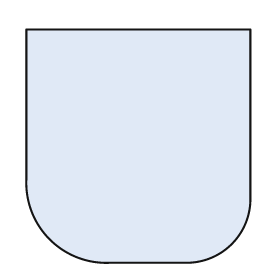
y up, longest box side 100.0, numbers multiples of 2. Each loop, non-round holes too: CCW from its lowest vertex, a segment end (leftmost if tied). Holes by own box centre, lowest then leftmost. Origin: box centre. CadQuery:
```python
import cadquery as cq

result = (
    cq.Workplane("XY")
    .moveTo(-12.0, -50.0)
    .lineTo(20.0, -50.0)
    .threePointArc((40.0, -42.0), (48.0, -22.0))
    .lineTo(48.0, 50.0)
    .lineTo(-48.0, 50.0)
    .lineTo(-48.0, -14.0)
    .threePointArc((-38.0, -40.0), (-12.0, -50.0))
    .close()
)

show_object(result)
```